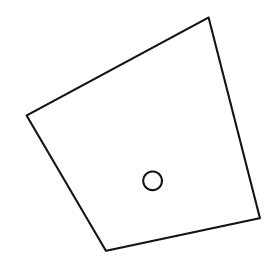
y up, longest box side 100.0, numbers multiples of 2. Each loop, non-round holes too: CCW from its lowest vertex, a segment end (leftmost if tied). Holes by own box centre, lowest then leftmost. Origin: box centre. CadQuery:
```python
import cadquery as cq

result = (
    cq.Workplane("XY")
    .moveTo(-16.0, -50.0)
    .lineTo(50.0, -36.0)
    .lineTo(28.0, 50.0)
    .lineTo(-50.0, 8.0)
    .close()
    .moveTo(4.0, -20.0)
    .circle(4.0)
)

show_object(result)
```